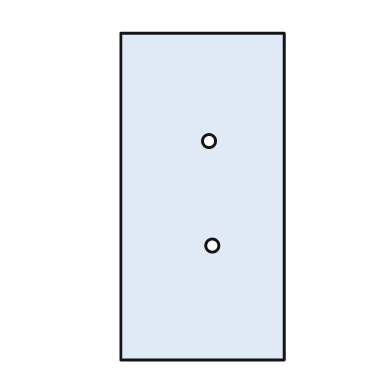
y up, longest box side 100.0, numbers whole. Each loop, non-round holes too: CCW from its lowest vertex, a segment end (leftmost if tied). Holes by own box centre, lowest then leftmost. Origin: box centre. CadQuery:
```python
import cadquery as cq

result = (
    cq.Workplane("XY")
    .moveTo(-25.0, -50.0)
    .lineTo(25.0, -50.0)
    .lineTo(25.0, 50.0)
    .lineTo(-25.0, 50.0)
    .close()
    .moveTo(3.0, -15.0)
    .circle(2.0)
    .moveTo(2.0, 17.0)
    .circle(2.0)
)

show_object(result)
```